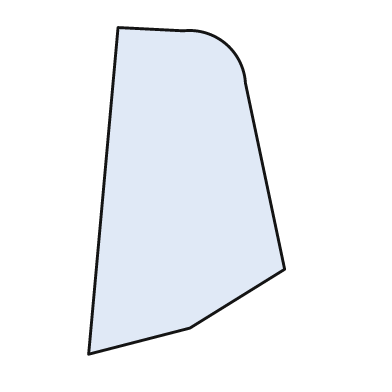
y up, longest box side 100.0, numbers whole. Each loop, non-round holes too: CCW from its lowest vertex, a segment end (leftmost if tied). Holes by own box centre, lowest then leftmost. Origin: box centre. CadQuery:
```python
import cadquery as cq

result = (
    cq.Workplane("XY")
    .moveTo(-30.0, -50.0)
    .lineTo(1.0, -42.0)
    .lineTo(30.0, -24.0)
    .lineTo(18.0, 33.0)
    .threePointArc((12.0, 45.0), (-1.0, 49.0))
    .lineTo(-21.0, 50.0)
    .close()
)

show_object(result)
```